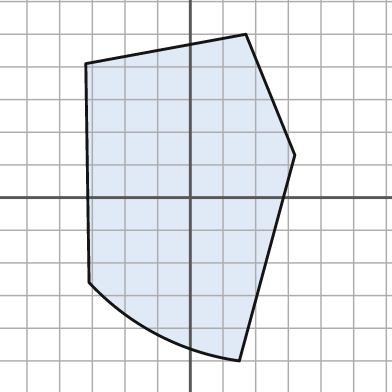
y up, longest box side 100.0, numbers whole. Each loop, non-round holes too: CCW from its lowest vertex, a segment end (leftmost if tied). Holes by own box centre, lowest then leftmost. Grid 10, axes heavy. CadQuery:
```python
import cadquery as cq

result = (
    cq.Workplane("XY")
    .moveTo(15.0, -50.0)
    .lineTo(32.0, 13.0)
    .lineTo(17.0, 50.0)
    .lineTo(-32.0, 41.0)
    .lineTo(-31.0, -26.0)
    .threePointArc((-10.0, -42.0), (15.0, -50.0))
    .close()
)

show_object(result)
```